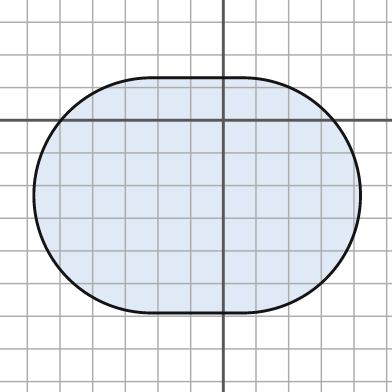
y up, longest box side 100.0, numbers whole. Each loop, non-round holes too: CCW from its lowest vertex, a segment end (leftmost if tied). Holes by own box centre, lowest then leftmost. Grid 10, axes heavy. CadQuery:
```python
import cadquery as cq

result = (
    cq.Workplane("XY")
    .moveTo(-22.0, -59.0)
    .lineTo(6.0, -59.0)
    .threePointArc((42.0, -23.0), (6.0, 13.0))
    .lineTo(-22.0, 13.0)
    .threePointArc((-58.0, -23.0), (-22.0, -59.0))
    .close()
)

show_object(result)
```